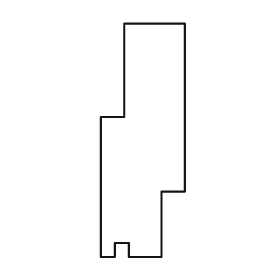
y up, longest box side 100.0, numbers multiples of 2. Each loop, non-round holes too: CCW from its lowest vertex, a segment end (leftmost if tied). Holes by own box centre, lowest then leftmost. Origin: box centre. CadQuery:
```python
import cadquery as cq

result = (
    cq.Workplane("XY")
    .moveTo(-18.0, -50.0)
    .lineTo(-12.0, -50.0)
    .lineTo(-12.0, -44.0)
    .lineTo(-6.0, -44.0)
    .lineTo(-6.0, -50.0)
    .lineTo(8.0, -50.0)
    .lineTo(8.0, -22.0)
    .lineTo(18.0, -22.0)
    .lineTo(18.0, 50.0)
    .lineTo(-8.0, 50.0)
    .lineTo(-8.0, 10.0)
    .lineTo(-18.0, 10.0)
    .close()
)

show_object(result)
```